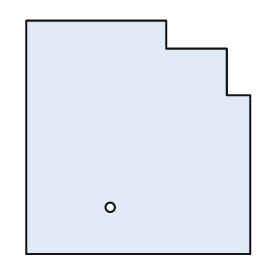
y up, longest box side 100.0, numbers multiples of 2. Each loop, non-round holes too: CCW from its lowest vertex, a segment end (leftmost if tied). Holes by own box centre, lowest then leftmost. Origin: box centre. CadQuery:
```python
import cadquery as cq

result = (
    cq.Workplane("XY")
    .moveTo(-48.0, -50.0)
    .lineTo(48.0, -50.0)
    .lineTo(48.0, 18.0)
    .lineTo(38.0, 18.0)
    .lineTo(38.0, 38.0)
    .lineTo(12.0, 38.0)
    .lineTo(12.0, 50.0)
    .lineTo(-48.0, 50.0)
    .close()
    .moveTo(-12.0, -30.0)
    .circle(2.0)
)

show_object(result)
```